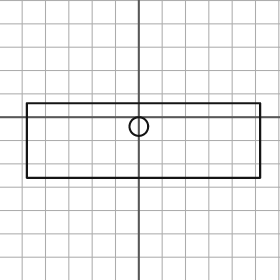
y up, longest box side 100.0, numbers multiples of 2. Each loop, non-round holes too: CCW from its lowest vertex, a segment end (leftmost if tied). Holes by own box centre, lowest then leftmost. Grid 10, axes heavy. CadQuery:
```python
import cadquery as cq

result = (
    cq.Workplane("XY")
    .moveTo(-48.0, -26.0)
    .lineTo(52.0, -26.0)
    .lineTo(52.0, 6.0)
    .lineTo(-48.0, 6.0)
    .close()
    .moveTo(0.0, -4.0)
    .circle(4.0)
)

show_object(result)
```